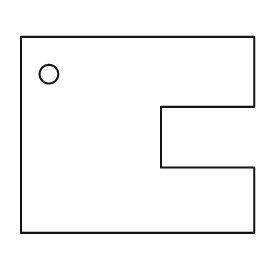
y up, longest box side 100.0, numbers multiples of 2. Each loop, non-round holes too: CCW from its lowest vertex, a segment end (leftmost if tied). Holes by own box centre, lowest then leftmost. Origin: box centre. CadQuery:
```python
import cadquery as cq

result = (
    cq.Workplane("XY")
    .moveTo(-50.0, -42.0)
    .lineTo(50.0, -42.0)
    .lineTo(50.0, -14.0)
    .lineTo(10.0, -14.0)
    .lineTo(10.0, 12.0)
    .lineTo(50.0, 12.0)
    .lineTo(50.0, 42.0)
    .lineTo(-50.0, 42.0)
    .close()
    .moveTo(-38.0, 26.0)
    .circle(4.0)
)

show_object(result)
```